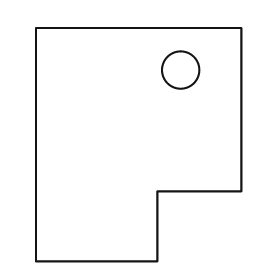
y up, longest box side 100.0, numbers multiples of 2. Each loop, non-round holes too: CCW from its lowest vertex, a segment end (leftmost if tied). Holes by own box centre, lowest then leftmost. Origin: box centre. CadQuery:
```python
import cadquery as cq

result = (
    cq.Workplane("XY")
    .moveTo(-44.0, -50.0)
    .lineTo(8.0, -50.0)
    .lineTo(8.0, -20.0)
    .lineTo(44.0, -20.0)
    .lineTo(44.0, 50.0)
    .lineTo(-44.0, 50.0)
    .close()
    .moveTo(18.0, 32.0)
    .circle(8.0)
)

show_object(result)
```